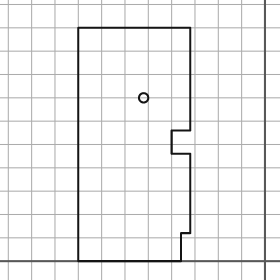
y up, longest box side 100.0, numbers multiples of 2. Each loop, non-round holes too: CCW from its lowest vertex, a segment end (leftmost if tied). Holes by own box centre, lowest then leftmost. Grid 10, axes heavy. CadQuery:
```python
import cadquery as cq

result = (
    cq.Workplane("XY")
    .moveTo(-80.0, 0.0)
    .lineTo(-36.0, 0.0)
    .lineTo(-36.0, 12.0)
    .lineTo(-32.0, 12.0)
    .lineTo(-32.0, 46.0)
    .lineTo(-40.0, 46.0)
    .lineTo(-40.0, 56.0)
    .lineTo(-32.0, 56.0)
    .lineTo(-32.0, 100.0)
    .lineTo(-80.0, 100.0)
    .close()
    .moveTo(-52.0, 70.0)
    .circle(2.0)
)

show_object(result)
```